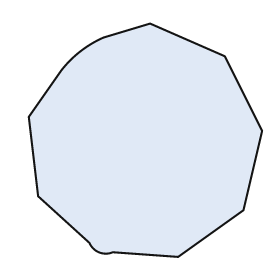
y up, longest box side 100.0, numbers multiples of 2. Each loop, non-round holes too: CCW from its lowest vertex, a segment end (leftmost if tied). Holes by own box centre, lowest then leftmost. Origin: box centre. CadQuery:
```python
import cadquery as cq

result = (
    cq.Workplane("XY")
    .moveTo(14.0, -50.0)
    .lineTo(42.0, -30.0)
    .lineTo(50.0, 4.0)
    .lineTo(34.0, 36.0)
    .lineTo(2.0, 50.0)
    .lineTo(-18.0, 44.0)
    .threePointArc((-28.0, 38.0), (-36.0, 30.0))
    .lineTo(-50.0, 10.0)
    .lineTo(-46.0, -24.0)
    .lineTo(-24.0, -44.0)
    .threePointArc((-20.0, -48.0), (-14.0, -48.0))
    .close()
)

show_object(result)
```